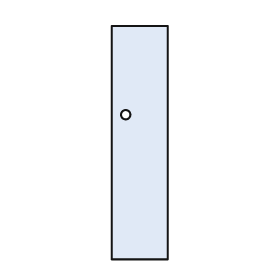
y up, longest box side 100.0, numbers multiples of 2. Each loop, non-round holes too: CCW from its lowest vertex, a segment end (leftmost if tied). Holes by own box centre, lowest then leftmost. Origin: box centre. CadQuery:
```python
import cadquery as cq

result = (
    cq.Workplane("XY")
    .moveTo(-12.0, -50.0)
    .lineTo(12.0, -50.0)
    .lineTo(12.0, 50.0)
    .lineTo(-12.0, 50.0)
    .close()
    .moveTo(-6.0, 12.0)
    .circle(2.0)
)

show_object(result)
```